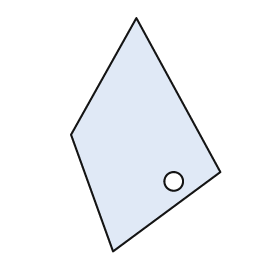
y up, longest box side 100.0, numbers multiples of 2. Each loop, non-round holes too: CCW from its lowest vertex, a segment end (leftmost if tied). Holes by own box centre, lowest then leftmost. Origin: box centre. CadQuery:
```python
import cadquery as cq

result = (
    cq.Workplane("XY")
    .moveTo(-14.0, -50.0)
    .lineTo(32.0, -16.0)
    .lineTo(-4.0, 50.0)
    .lineTo(-32.0, 0.0)
    .close()
    .moveTo(12.0, -20.0)
    .circle(4.0)
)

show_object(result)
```